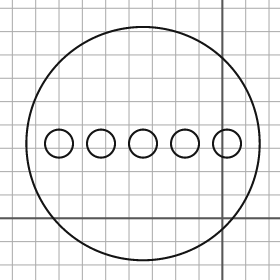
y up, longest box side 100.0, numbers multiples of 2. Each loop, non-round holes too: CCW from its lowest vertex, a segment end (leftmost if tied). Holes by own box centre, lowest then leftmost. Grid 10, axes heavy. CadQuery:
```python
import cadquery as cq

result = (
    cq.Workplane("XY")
    .moveTo(-34.0, 32.0)
    .circle(50.0)
    .moveTo(-70.0, 32.0)
    .circle(6.0)
    .moveTo(-52.0, 32.0)
    .circle(6.0)
    .moveTo(-34.0, 32.0)
    .circle(6.0)
    .moveTo(-16.0, 32.0)
    .circle(6.0)
    .moveTo(2.0, 32.0)
    .circle(6.0)
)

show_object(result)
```